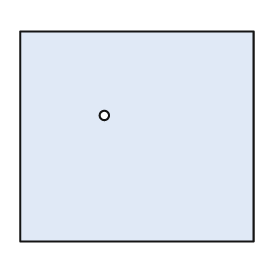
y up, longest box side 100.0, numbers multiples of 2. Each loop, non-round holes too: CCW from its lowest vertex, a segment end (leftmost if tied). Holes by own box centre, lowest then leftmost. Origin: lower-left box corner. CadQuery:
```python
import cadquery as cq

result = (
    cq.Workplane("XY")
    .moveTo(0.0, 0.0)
    .lineTo(100.0, 0.0)
    .lineTo(100.0, 90.0)
    .lineTo(0.0, 90.0)
    .close()
    .moveTo(36.0, 54.0)
    .circle(2.0)
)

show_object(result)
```